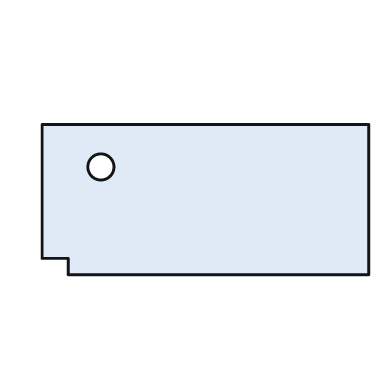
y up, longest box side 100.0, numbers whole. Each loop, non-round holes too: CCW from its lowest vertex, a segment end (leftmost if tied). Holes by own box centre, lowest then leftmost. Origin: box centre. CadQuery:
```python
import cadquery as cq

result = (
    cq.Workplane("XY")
    .moveTo(-42.0, -23.0)
    .lineTo(50.0, -23.0)
    .lineTo(50.0, 23.0)
    .lineTo(-50.0, 23.0)
    .lineTo(-50.0, -18.0)
    .lineTo(-42.0, -18.0)
    .close()
    .moveTo(-32.0, 10.0)
    .circle(4.0)
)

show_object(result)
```